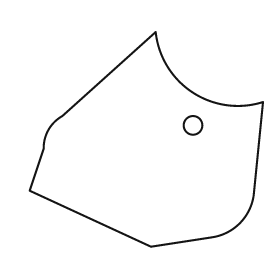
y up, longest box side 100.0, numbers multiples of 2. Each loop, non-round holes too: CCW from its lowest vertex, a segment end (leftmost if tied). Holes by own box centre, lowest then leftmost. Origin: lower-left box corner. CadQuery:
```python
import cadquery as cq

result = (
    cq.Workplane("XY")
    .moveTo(52.0, 0.0)
    .lineTo(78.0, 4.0)
    .threePointArc((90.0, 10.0), (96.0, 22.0))
    .lineTo(100.0, 62.0)
    .threePointArc((70.0, 66.0), (54.0, 92.0))
    .lineTo(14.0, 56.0)
    .threePointArc((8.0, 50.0), (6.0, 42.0))
    .lineTo(0.0, 24.0)
    .close()
    .moveTo(70.0, 52.0)
    .circle(4.0)
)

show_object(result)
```